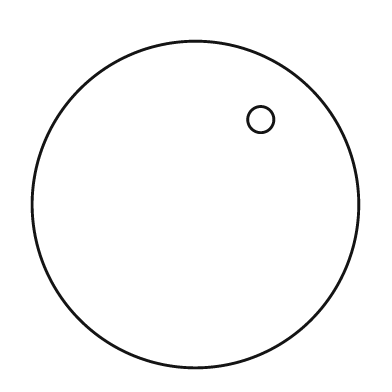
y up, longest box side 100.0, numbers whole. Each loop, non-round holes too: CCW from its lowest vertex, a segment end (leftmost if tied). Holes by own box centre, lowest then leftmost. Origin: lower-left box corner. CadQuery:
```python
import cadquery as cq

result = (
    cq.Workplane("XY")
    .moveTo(50.0, 50.0)
    .circle(50.0)
    .moveTo(70.0, 76.0)
    .circle(4.0)
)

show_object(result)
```